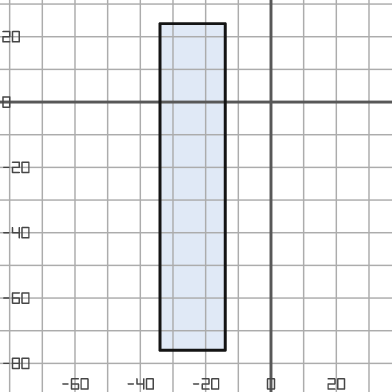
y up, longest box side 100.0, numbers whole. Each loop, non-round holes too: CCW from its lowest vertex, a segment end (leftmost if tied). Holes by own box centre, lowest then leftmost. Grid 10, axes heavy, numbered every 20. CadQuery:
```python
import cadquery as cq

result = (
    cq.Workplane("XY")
    .moveTo(-34.0, -76.0)
    .lineTo(-14.0, -76.0)
    .lineTo(-14.0, 24.0)
    .lineTo(-34.0, 24.0)
    .close()
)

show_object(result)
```